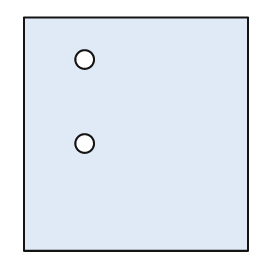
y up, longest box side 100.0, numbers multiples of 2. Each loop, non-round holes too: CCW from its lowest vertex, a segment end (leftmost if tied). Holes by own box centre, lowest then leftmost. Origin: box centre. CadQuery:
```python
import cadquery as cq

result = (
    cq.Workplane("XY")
    .moveTo(-48.0, -50.0)
    .lineTo(48.0, -50.0)
    .lineTo(48.0, 50.0)
    .lineTo(-48.0, 50.0)
    .close()
    .moveTo(-22.0, -4.0)
    .circle(4.0)
    .moveTo(-22.0, 32.0)
    .circle(4.0)
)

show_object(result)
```